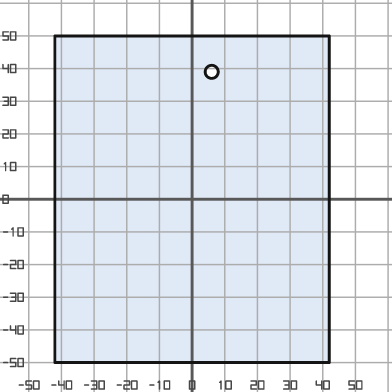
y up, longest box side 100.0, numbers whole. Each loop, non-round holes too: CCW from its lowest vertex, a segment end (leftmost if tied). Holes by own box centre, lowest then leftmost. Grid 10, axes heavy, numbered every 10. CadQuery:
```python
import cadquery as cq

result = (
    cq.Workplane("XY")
    .moveTo(-42.0, -50.0)
    .lineTo(42.0, -50.0)
    .lineTo(42.0, 50.0)
    .lineTo(-42.0, 50.0)
    .close()
    .moveTo(6.0, 39.0)
    .circle(2.0)
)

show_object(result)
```